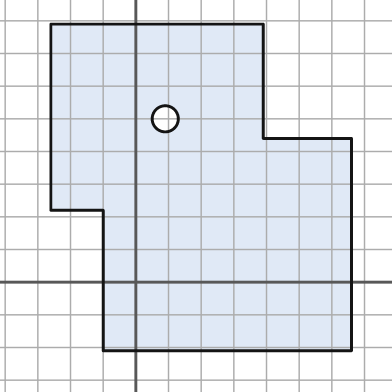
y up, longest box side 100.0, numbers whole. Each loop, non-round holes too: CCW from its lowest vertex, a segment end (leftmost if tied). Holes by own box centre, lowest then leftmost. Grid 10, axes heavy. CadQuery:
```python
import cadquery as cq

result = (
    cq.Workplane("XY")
    .moveTo(-10.0, -21.0)
    .lineTo(66.0, -21.0)
    .lineTo(66.0, 44.0)
    .lineTo(39.0, 44.0)
    .lineTo(39.0, 79.0)
    .lineTo(-26.0, 79.0)
    .lineTo(-26.0, 22.0)
    .lineTo(-10.0, 22.0)
    .close()
    .moveTo(9.0, 50.0)
    .circle(4.0)
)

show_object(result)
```